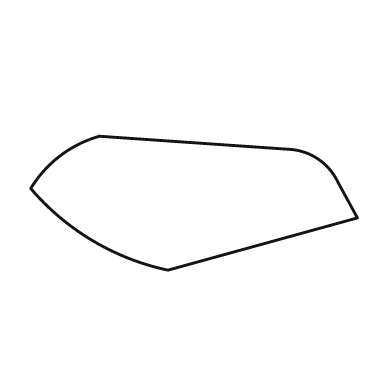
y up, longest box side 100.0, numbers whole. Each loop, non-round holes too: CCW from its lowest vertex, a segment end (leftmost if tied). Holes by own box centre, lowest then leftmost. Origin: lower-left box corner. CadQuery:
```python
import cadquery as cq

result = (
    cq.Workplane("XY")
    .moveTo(42.0, 0.0)
    .lineTo(100.0, 16.0)
    .lineTo(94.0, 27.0)
    .threePointArc((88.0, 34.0), (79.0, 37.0))
    .lineTo(21.0, 41.0)
    .threePointArc((9.0, 35.0), (0.0, 25.0))
    .threePointArc((19.0, 9.0), (42.0, 0.0))
    .close()
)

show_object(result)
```